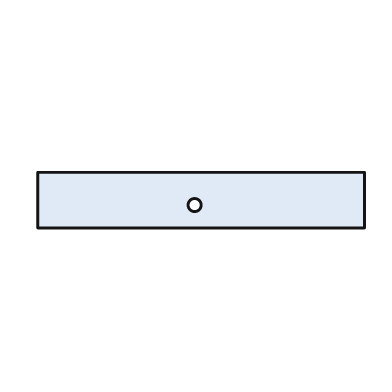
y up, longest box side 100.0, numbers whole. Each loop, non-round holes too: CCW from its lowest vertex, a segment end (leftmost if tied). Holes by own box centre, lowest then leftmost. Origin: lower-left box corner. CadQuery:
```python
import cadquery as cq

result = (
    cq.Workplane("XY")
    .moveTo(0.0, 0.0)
    .lineTo(100.0, 0.0)
    .lineTo(100.0, 17.0)
    .lineTo(0.0, 17.0)
    .close()
    .moveTo(48.0, 7.0)
    .circle(2.0)
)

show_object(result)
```